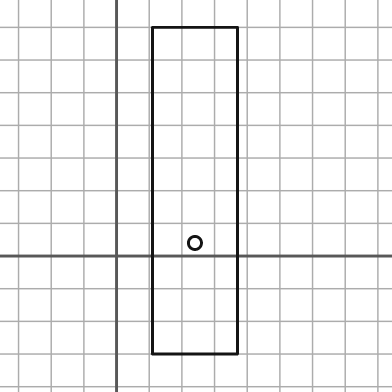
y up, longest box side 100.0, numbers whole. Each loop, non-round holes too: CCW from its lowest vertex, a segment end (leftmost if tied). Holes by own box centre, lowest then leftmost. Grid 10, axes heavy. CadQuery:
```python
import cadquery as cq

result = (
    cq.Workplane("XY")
    .moveTo(11.0, -30.0)
    .lineTo(37.0, -30.0)
    .lineTo(37.0, 70.0)
    .lineTo(11.0, 70.0)
    .close()
    .moveTo(24.0, 4.0)
    .circle(2.0)
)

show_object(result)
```